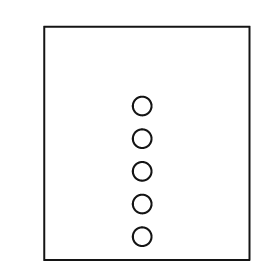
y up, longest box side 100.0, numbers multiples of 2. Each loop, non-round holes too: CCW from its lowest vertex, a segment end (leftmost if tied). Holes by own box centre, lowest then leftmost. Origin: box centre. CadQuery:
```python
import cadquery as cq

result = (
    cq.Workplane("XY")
    .moveTo(-44.0, -50.0)
    .lineTo(44.0, -50.0)
    .lineTo(44.0, 50.0)
    .lineTo(-44.0, 50.0)
    .close()
    .moveTo(-2.0, -40.0)
    .circle(4.0)
    .moveTo(-2.0, -26.0)
    .circle(4.0)
    .moveTo(-2.0, -12.0)
    .circle(4.0)
    .moveTo(-2.0, 2.0)
    .circle(4.0)
    .moveTo(-2.0, 16.0)
    .circle(4.0)
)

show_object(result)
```